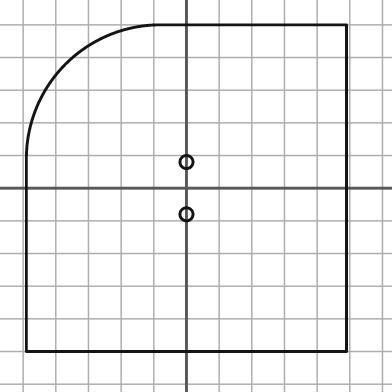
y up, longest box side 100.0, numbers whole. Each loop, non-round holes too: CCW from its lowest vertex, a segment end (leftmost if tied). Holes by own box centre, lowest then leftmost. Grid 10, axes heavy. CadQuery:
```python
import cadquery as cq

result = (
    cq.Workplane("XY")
    .moveTo(-49.0, -50.0)
    .lineTo(49.0, -50.0)
    .lineTo(49.0, 50.0)
    .lineTo(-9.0, 50.0)
    .threePointArc((-37.0, 38.0), (-49.0, 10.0))
    .close()
    .moveTo(0.0, -8.0)
    .circle(2.0)
    .moveTo(0.0, 8.0)
    .circle(2.0)
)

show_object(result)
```